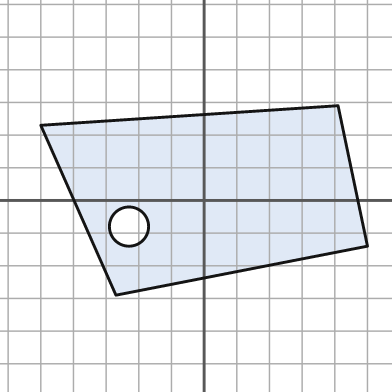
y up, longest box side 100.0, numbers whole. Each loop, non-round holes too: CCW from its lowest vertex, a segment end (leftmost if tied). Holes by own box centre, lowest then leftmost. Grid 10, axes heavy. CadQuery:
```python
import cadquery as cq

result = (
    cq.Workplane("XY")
    .moveTo(-27.0, -29.0)
    .lineTo(50.0, -14.0)
    .lineTo(41.0, 29.0)
    .lineTo(-50.0, 23.0)
    .close()
    .moveTo(-23.0, -8.0)
    .circle(6.0)
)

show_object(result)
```